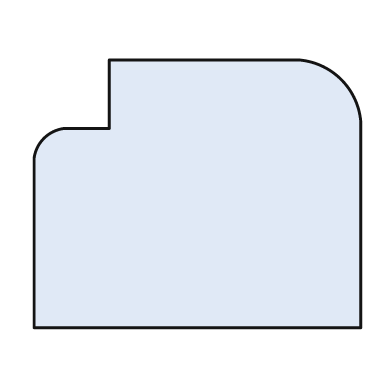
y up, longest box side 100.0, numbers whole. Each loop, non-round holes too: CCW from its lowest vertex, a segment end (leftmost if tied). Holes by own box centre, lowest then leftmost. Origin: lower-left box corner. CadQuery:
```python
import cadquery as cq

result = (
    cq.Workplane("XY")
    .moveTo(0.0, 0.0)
    .lineTo(100.0, 0.0)
    .lineTo(100.0, 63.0)
    .threePointArc((94.0, 76.0), (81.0, 82.0))
    .lineTo(23.0, 82.0)
    .lineTo(23.0, 61.0)
    .lineTo(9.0, 61.0)
    .threePointArc((3.0, 58.0), (0.0, 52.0))
    .close()
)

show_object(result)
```